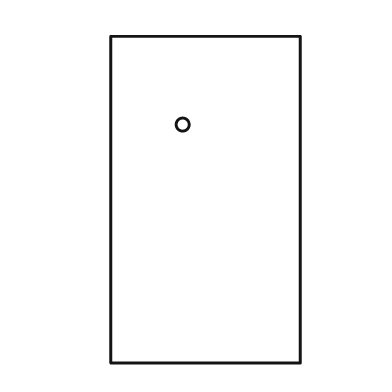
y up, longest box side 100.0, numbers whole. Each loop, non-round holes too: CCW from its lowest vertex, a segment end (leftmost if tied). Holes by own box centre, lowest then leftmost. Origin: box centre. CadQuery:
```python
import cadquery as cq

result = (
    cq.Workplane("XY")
    .moveTo(-29.0, -50.0)
    .lineTo(29.0, -50.0)
    .lineTo(29.0, 50.0)
    .lineTo(-29.0, 50.0)
    .close()
    .moveTo(-7.0, 23.0)
    .circle(2.0)
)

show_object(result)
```